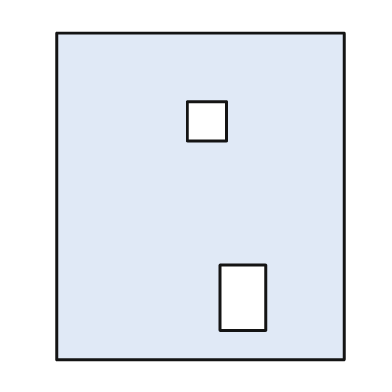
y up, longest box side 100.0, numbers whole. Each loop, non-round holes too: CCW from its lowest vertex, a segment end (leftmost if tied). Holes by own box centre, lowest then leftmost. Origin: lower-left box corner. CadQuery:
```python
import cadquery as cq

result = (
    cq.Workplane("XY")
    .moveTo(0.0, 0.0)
    .lineTo(88.0, 0.0)
    .lineTo(88.0, 100.0)
    .lineTo(0.0, 100.0)
    .close()
    .moveTo(50.0, 9.0)
    .lineTo(64.0, 9.0)
    .lineTo(64.0, 29.0)
    .lineTo(50.0, 29.0)
    .close()
    .moveTo(40.0, 67.0)
    .lineTo(52.0, 67.0)
    .lineTo(52.0, 79.0)
    .lineTo(40.0, 79.0)
    .close()
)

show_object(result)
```